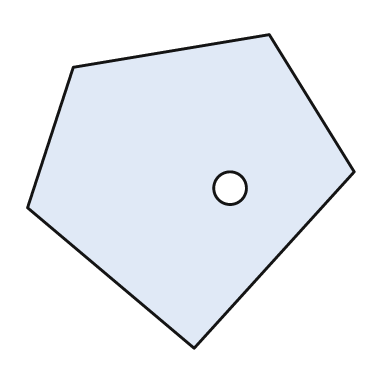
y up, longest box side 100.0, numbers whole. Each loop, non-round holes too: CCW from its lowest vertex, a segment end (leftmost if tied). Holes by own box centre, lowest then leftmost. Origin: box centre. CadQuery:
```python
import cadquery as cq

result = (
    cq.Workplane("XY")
    .moveTo(1.0, -48.0)
    .lineTo(50.0, 6.0)
    .lineTo(24.0, 48.0)
    .lineTo(-36.0, 38.0)
    .lineTo(-50.0, -5.0)
    .close()
    .moveTo(12.0, 1.0)
    .circle(5.0)
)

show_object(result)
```